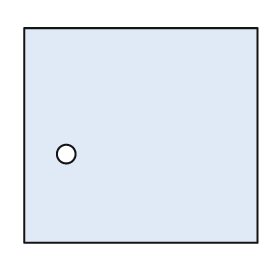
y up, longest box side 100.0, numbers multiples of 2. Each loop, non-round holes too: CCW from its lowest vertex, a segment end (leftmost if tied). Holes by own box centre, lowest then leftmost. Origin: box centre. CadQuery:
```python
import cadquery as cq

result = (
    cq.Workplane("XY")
    .moveTo(-50.0, -46.0)
    .lineTo(50.0, -46.0)
    .lineTo(50.0, 46.0)
    .lineTo(-50.0, 46.0)
    .close()
    .moveTo(-32.0, -8.0)
    .circle(4.0)
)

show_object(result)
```